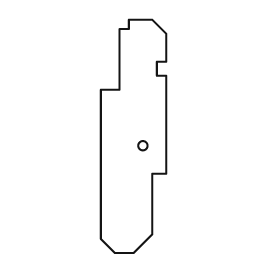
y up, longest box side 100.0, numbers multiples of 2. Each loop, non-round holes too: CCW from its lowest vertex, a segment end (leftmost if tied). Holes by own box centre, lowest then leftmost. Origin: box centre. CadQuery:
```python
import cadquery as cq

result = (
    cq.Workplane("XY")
    .moveTo(-8.0, -50.0)
    .lineTo(0.0, -50.0)
    .lineTo(8.0, -42.0)
    .lineTo(8.0, -16.0)
    .lineTo(14.0, -16.0)
    .lineTo(14.0, 26.0)
    .lineTo(10.0, 26.0)
    .lineTo(10.0, 32.0)
    .lineTo(14.0, 32.0)
    .lineTo(14.0, 44.0)
    .lineTo(8.0, 50.0)
    .lineTo(-2.0, 50.0)
    .lineTo(-2.0, 46.0)
    .lineTo(-6.0, 46.0)
    .lineTo(-6.0, 20.0)
    .lineTo(-14.0, 20.0)
    .lineTo(-14.0, -44.0)
    .close()
    .moveTo(4.0, -4.0)
    .circle(2.0)
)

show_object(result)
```